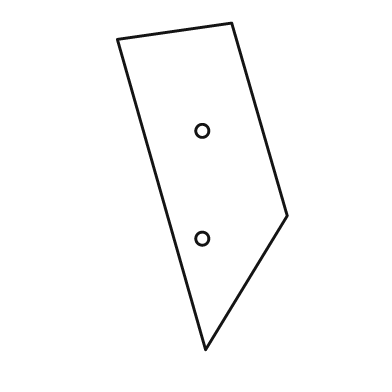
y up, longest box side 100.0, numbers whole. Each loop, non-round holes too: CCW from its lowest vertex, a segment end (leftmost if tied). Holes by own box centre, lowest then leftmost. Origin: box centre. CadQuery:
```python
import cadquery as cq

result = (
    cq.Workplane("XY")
    .moveTo(1.0, -50.0)
    .lineTo(26.0, -9.0)
    .lineTo(9.0, 50.0)
    .lineTo(-26.0, 45.0)
    .close()
    .moveTo(0.0, -16.0)
    .circle(2.0)
    .moveTo(0.0, 17.0)
    .circle(2.0)
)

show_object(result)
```